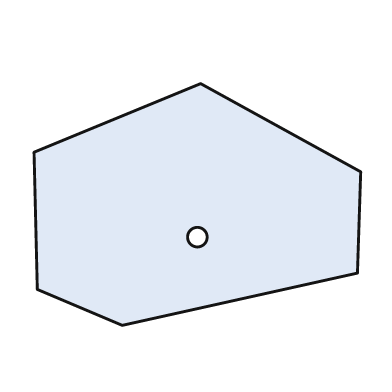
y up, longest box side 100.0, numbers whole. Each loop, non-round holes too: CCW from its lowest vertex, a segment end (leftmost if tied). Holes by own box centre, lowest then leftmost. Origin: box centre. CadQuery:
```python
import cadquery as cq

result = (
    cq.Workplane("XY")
    .moveTo(-23.0, -37.0)
    .lineTo(49.0, -21.0)
    .lineTo(50.0, 10.0)
    .lineTo(1.0, 37.0)
    .lineTo(-50.0, 16.0)
    .lineTo(-49.0, -26.0)
    .close()
    .moveTo(0.0, -10.0)
    .circle(3.0)
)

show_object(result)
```